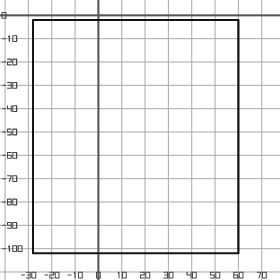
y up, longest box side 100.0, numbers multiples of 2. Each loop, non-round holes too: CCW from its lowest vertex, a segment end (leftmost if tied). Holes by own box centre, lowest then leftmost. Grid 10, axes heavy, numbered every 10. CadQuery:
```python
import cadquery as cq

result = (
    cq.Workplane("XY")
    .moveTo(-28.0, -102.0)
    .lineTo(60.0, -102.0)
    .lineTo(60.0, -2.0)
    .lineTo(-28.0, -2.0)
    .close()
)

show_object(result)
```